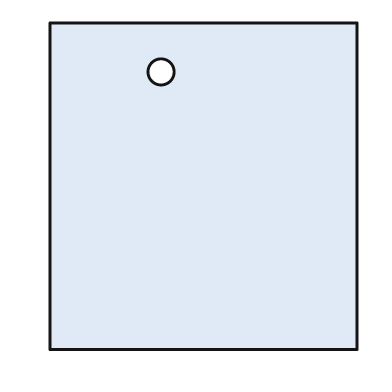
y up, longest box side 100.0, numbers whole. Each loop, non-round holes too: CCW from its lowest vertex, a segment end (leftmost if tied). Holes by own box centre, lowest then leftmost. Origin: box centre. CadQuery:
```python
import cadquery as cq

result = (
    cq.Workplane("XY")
    .moveTo(-47.0, -50.0)
    .lineTo(47.0, -50.0)
    .lineTo(47.0, 50.0)
    .lineTo(-47.0, 50.0)
    .close()
    .moveTo(-13.0, 35.0)
    .circle(4.0)
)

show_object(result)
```